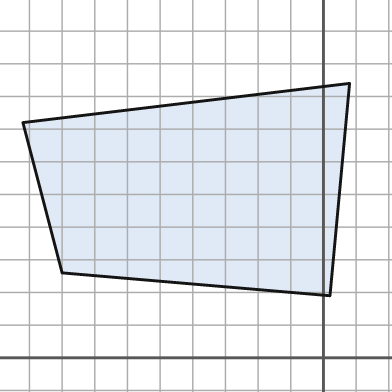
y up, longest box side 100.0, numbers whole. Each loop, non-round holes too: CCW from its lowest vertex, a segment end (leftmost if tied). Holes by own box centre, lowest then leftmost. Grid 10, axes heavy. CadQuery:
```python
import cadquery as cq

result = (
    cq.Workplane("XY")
    .moveTo(2.0, 19.0)
    .lineTo(8.0, 84.0)
    .lineTo(-92.0, 72.0)
    .lineTo(-80.0, 26.0)
    .close()
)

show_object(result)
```